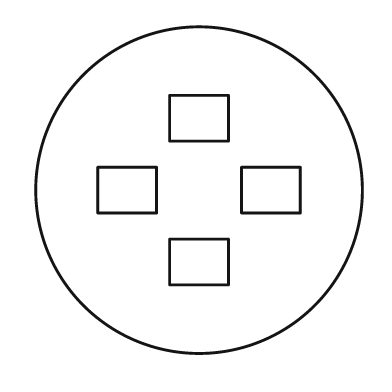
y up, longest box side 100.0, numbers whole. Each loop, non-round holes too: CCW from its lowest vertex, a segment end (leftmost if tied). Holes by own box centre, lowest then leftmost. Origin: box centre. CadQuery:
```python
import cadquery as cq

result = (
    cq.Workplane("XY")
    .moveTo(0.0, 0.0)
    .circle(50.0)
    .moveTo(-9.0, -29.0)
    .lineTo(9.0, -29.0)
    .lineTo(9.0, -15.0)
    .lineTo(-9.0, -15.0)
    .close()
    .moveTo(-31.0, -7.0)
    .lineTo(-13.0, -7.0)
    .lineTo(-13.0, 7.0)
    .lineTo(-31.0, 7.0)
    .close()
    .moveTo(13.0, -7.0)
    .lineTo(31.0, -7.0)
    .lineTo(31.0, 7.0)
    .lineTo(13.0, 7.0)
    .close()
    .moveTo(-9.0, 15.0)
    .lineTo(9.0, 15.0)
    .lineTo(9.0, 29.0)
    .lineTo(-9.0, 29.0)
    .close()
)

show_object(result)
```